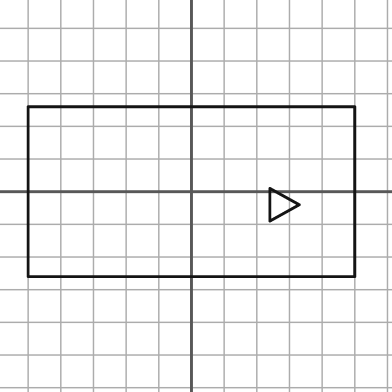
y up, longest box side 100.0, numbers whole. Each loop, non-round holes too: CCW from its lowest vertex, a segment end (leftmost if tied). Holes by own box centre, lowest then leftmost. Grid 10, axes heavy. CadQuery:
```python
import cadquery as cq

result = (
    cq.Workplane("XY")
    .moveTo(-50.0, -26.0)
    .lineTo(50.0, -26.0)
    .lineTo(50.0, 26.0)
    .lineTo(-50.0, 26.0)
    .close()
    .moveTo(24.0, -9.0)
    .lineTo(33.0, -4.0)
    .lineTo(24.0, 1.0)
    .close()
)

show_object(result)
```